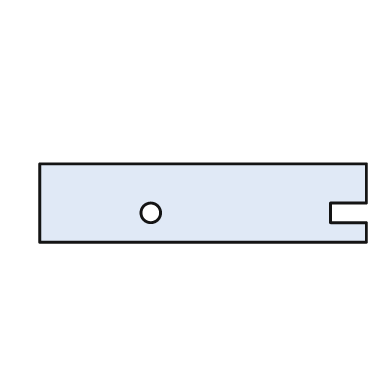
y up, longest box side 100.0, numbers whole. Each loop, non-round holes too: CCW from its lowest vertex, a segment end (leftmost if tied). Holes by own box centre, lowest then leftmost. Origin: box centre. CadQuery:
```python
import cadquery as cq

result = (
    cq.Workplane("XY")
    .moveTo(-50.0, -12.0)
    .lineTo(50.0, -12.0)
    .lineTo(50.0, -6.0)
    .lineTo(39.0, -6.0)
    .lineTo(39.0, 0.0)
    .lineTo(50.0, 0.0)
    .lineTo(50.0, 12.0)
    .lineTo(-50.0, 12.0)
    .close()
    .moveTo(-16.0, -3.0)
    .circle(3.0)
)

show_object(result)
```